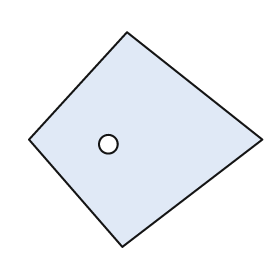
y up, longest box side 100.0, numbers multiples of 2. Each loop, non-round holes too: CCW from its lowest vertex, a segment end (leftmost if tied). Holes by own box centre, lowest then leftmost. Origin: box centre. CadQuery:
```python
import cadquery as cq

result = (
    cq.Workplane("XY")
    .moveTo(-10.0, -46.0)
    .lineTo(50.0, 0.0)
    .lineTo(-8.0, 46.0)
    .lineTo(-50.0, 0.0)
    .close()
    .moveTo(-16.0, -2.0)
    .circle(4.0)
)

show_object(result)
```